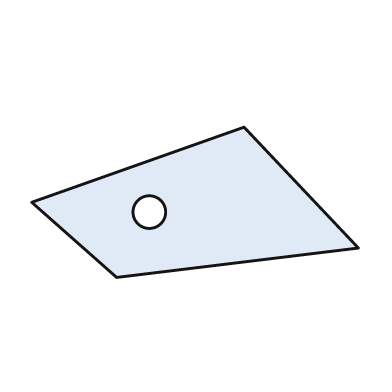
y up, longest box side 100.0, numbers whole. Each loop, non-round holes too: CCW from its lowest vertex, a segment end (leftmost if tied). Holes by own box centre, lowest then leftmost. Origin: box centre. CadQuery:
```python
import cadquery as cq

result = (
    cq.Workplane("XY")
    .moveTo(-24.0, -23.0)
    .lineTo(50.0, -14.0)
    .lineTo(15.0, 23.0)
    .lineTo(-50.0, 0.0)
    .close()
    .moveTo(-14.0, -3.0)
    .circle(5.0)
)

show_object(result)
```